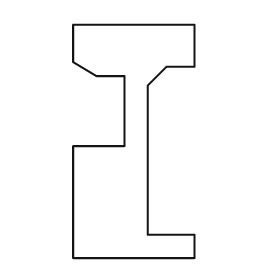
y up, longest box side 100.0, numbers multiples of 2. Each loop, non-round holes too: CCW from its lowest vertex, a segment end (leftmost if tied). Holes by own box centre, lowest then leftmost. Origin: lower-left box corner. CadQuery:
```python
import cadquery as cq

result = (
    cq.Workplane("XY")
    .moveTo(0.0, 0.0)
    .lineTo(52.0, 0.0)
    .lineTo(52.0, 10.0)
    .lineTo(32.0, 10.0)
    .lineTo(32.0, 74.0)
    .lineTo(40.0, 82.0)
    .lineTo(52.0, 82.0)
    .lineTo(52.0, 100.0)
    .lineTo(0.0, 100.0)
    .lineTo(0.0, 84.0)
    .lineTo(10.0, 78.0)
    .lineTo(22.0, 78.0)
    .lineTo(22.0, 48.0)
    .lineTo(0.0, 48.0)
    .close()
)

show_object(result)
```